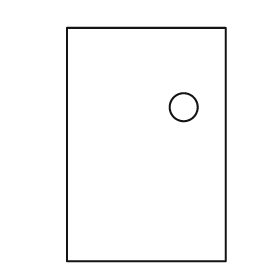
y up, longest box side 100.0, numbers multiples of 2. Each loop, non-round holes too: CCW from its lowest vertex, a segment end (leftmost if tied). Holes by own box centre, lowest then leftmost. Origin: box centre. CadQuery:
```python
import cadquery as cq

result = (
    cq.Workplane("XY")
    .moveTo(-34.0, -50.0)
    .lineTo(34.0, -50.0)
    .lineTo(34.0, 50.0)
    .lineTo(-34.0, 50.0)
    .close()
    .moveTo(16.0, 16.0)
    .circle(6.0)
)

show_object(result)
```